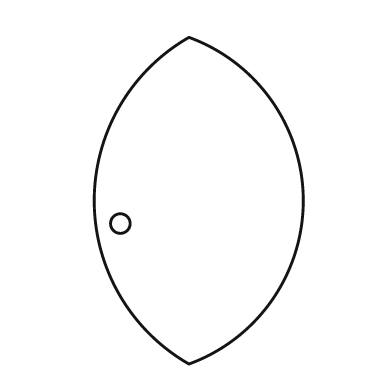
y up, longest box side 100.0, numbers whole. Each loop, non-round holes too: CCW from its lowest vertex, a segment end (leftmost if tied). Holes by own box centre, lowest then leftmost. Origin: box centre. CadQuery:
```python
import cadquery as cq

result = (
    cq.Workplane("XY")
    .moveTo(-3.0, -50.0)
    .threePointArc((32.0, 0.0), (-3.0, 50.0))
    .threePointArc((-32.0, 0.0), (-3.0, -50.0))
    .close()
    .moveTo(-24.0, -7.0)
    .circle(3.0)
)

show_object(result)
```